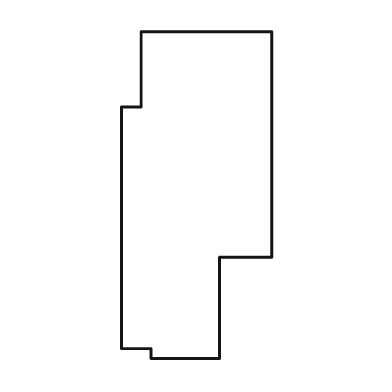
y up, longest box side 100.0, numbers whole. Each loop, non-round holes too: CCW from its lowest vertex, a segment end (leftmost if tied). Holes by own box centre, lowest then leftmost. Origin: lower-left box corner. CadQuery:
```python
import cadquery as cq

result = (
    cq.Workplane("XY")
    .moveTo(9.0, 0.0)
    .lineTo(30.0, 0.0)
    .lineTo(30.0, 31.0)
    .lineTo(46.0, 31.0)
    .lineTo(46.0, 100.0)
    .lineTo(6.0, 100.0)
    .lineTo(6.0, 77.0)
    .lineTo(0.0, 77.0)
    .lineTo(0.0, 3.0)
    .lineTo(9.0, 3.0)
    .close()
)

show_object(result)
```